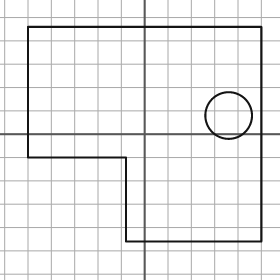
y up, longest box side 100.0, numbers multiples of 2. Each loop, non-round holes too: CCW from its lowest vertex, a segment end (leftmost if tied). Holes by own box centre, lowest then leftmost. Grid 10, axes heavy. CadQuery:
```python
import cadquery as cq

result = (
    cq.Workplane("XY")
    .moveTo(-8.0, -46.0)
    .lineTo(50.0, -46.0)
    .lineTo(50.0, 46.0)
    .lineTo(-50.0, 46.0)
    .lineTo(-50.0, -10.0)
    .lineTo(-8.0, -10.0)
    .close()
    .moveTo(36.0, 8.0)
    .circle(10.0)
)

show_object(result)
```